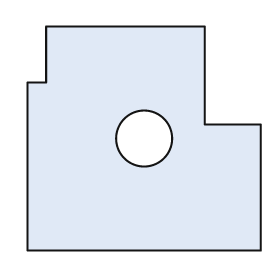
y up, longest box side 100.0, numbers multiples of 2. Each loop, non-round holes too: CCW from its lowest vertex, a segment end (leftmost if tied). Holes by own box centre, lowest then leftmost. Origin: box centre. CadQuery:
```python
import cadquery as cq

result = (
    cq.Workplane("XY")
    .moveTo(-50.0, -48.0)
    .lineTo(50.0, -48.0)
    .lineTo(50.0, 6.0)
    .lineTo(26.0, 6.0)
    .lineTo(26.0, 48.0)
    .lineTo(-42.0, 48.0)
    .lineTo(-42.0, 24.0)
    .lineTo(-50.0, 24.0)
    .close()
    .moveTo(0.0, 0.0)
    .circle(12.0)
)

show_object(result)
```